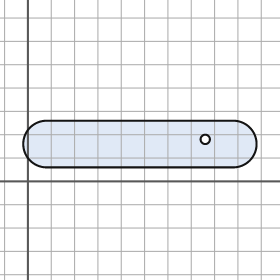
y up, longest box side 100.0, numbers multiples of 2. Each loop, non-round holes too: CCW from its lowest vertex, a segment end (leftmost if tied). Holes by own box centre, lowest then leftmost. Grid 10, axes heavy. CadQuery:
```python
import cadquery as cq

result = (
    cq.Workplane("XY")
    .moveTo(8.0, 6.0)
    .lineTo(88.0, 6.0)
    .threePointArc((98.0, 16.0), (88.0, 26.0))
    .lineTo(8.0, 26.0)
    .threePointArc((-2.0, 16.0), (8.0, 6.0))
    .close()
    .moveTo(76.0, 18.0)
    .circle(2.0)
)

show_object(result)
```